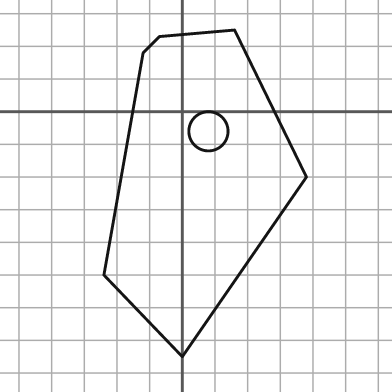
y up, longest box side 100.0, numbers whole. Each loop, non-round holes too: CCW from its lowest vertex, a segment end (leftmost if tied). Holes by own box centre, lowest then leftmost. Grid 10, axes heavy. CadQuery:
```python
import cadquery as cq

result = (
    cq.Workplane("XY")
    .moveTo(0.0, -75.0)
    .lineTo(38.0, -20.0)
    .lineTo(16.0, 25.0)
    .lineTo(-7.0, 23.0)
    .lineTo(-12.0, 18.0)
    .lineTo(-24.0, -50.0)
    .close()
    .moveTo(8.0, -6.0)
    .circle(6.0)
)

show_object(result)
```